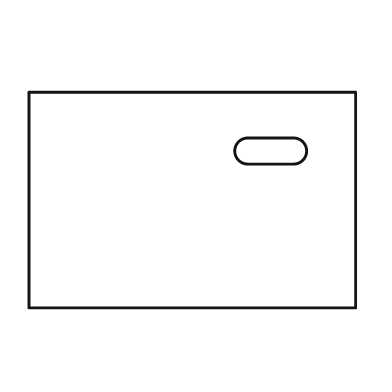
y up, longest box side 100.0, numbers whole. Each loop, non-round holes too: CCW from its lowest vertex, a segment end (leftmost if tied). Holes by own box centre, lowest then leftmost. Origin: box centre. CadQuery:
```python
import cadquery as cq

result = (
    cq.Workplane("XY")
    .moveTo(-50.0, -33.0)
    .lineTo(50.0, -33.0)
    .lineTo(50.0, 33.0)
    .lineTo(-50.0, 33.0)
    .close()
    .moveTo(17.0, 11.0)
    .lineTo(31.0, 11.0)
    .threePointArc((35.0, 15.0), (31.0, 19.0))
    .lineTo(17.0, 19.0)
    .threePointArc((13.0, 15.0), (17.0, 11.0))
    .close()
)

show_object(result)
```